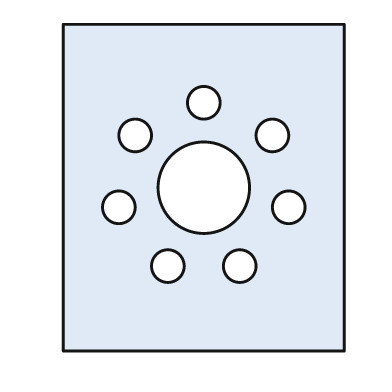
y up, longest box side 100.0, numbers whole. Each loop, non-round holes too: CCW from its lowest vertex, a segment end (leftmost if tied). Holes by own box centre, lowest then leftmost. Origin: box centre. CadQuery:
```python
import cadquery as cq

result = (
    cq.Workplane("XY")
    .moveTo(-43.0, -50.0)
    .lineTo(43.0, -50.0)
    .lineTo(43.0, 50.0)
    .lineTo(-43.0, 50.0)
    .close()
    .moveTo(-11.0, -24.0)
    .circle(5.0)
    .moveTo(11.0, -24.0)
    .circle(5.0)
    .moveTo(-26.0, -6.0)
    .circle(5.0)
    .moveTo(26.0, -6.0)
    .circle(5.0)
    .moveTo(0.0, 0.0)
    .circle(14.0)
    .moveTo(-21.0, 16.0)
    .circle(5.0)
    .moveTo(21.0, 16.0)
    .circle(5.0)
    .moveTo(0.0, 26.0)
    .circle(5.0)
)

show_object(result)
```